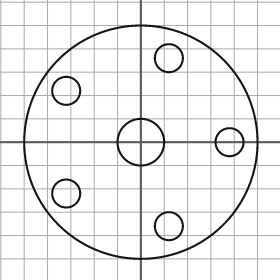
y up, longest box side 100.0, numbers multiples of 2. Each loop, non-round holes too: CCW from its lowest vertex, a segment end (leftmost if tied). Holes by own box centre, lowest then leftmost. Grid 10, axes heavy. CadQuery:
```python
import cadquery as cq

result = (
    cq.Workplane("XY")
    .moveTo(0.0, 0.0)
    .circle(50.0)
    .moveTo(12.0, -36.0)
    .circle(6.0)
    .moveTo(-32.0, -22.0)
    .circle(6.0)
    .moveTo(0.0, 0.0)
    .circle(10.0)
    .moveTo(38.0, 0.0)
    .circle(6.0)
    .moveTo(-32.0, 22.0)
    .circle(6.0)
    .moveTo(12.0, 36.0)
    .circle(6.0)
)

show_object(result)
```